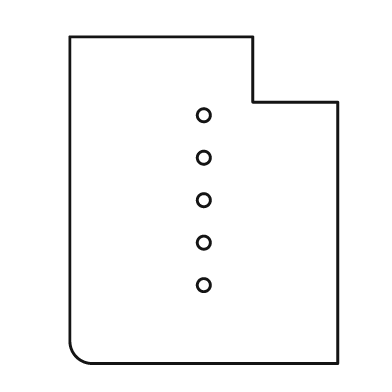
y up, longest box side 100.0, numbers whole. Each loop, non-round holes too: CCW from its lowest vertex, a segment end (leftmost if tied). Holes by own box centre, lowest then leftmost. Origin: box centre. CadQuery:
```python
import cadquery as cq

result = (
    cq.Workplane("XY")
    .moveTo(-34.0, -50.0)
    .lineTo(41.0, -50.0)
    .lineTo(41.0, 30.0)
    .lineTo(15.0, 30.0)
    .lineTo(15.0, 50.0)
    .lineTo(-41.0, 50.0)
    .lineTo(-41.0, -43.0)
    .threePointArc((-39.0, -48.0), (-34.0, -50.0))
    .close()
    .moveTo(0.0, -26.0)
    .circle(2.0)
    .moveTo(0.0, -13.0)
    .circle(2.0)
    .moveTo(0.0, 0.0)
    .circle(2.0)
    .moveTo(0.0, 13.0)
    .circle(2.0)
    .moveTo(0.0, 26.0)
    .circle(2.0)
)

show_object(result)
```